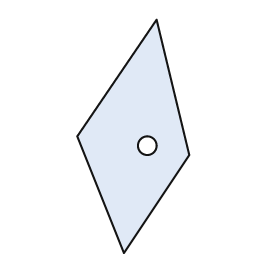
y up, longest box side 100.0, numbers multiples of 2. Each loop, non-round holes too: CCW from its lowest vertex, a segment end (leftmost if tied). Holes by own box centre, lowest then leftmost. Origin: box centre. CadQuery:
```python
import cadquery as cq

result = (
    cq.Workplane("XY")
    .moveTo(-4.0, -50.0)
    .lineTo(24.0, -8.0)
    .lineTo(10.0, 50.0)
    .lineTo(-24.0, 0.0)
    .close()
    .moveTo(6.0, -4.0)
    .circle(4.0)
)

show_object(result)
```